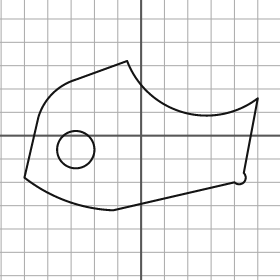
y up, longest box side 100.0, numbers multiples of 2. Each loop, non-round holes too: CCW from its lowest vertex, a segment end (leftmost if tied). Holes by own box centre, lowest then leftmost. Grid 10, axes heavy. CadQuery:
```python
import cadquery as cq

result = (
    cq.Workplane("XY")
    .moveTo(-12.0, -32.0)
    .lineTo(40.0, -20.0)
    .threePointArc((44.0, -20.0), (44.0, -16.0))
    .lineTo(50.0, 16.0)
    .threePointArc((18.0, 10.0), (-6.0, 32.0))
    .lineTo(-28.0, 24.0)
    .threePointArc((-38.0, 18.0), (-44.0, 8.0))
    .lineTo(-50.0, -18.0)
    .threePointArc((-32.0, -28.0), (-12.0, -32.0))
    .close()
    .moveTo(-28.0, -6.0)
    .circle(8.0)
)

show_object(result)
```